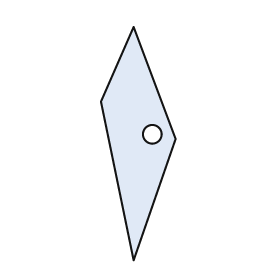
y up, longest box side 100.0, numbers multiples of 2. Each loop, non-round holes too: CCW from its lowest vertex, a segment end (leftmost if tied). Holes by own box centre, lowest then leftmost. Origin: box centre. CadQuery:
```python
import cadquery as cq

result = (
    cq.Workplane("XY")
    .moveTo(-2.0, -50.0)
    .lineTo(16.0, 2.0)
    .lineTo(-2.0, 50.0)
    .lineTo(-16.0, 18.0)
    .close()
    .moveTo(6.0, 4.0)
    .circle(4.0)
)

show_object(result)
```